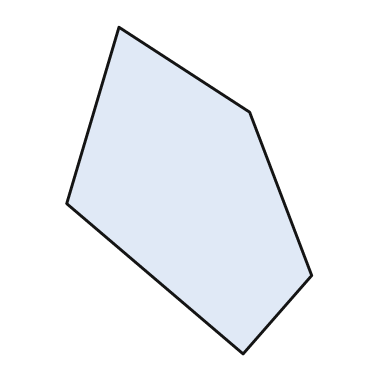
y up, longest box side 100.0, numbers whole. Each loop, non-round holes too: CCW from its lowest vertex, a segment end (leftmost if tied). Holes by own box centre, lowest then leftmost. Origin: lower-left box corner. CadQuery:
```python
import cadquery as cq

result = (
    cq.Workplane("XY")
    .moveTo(54.0, 0.0)
    .lineTo(75.0, 24.0)
    .lineTo(56.0, 74.0)
    .lineTo(16.0, 100.0)
    .lineTo(0.0, 46.0)
    .close()
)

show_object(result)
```